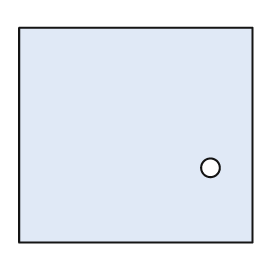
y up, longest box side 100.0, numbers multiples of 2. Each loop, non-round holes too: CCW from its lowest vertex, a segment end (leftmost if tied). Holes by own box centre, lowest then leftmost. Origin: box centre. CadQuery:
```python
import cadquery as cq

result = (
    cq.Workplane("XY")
    .moveTo(-50.0, -46.0)
    .lineTo(50.0, -46.0)
    .lineTo(50.0, 46.0)
    .lineTo(-50.0, 46.0)
    .close()
    .moveTo(32.0, -14.0)
    .circle(4.0)
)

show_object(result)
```